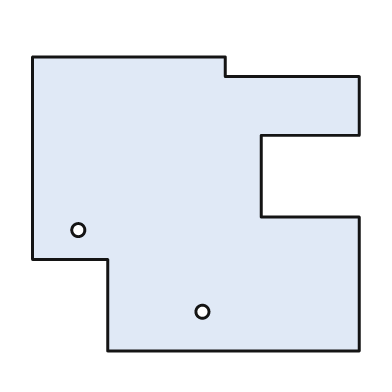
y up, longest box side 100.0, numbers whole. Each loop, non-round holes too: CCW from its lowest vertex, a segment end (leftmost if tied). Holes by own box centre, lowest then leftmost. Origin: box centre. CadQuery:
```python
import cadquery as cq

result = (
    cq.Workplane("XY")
    .moveTo(-27.0, -45.0)
    .lineTo(50.0, -45.0)
    .lineTo(50.0, -4.0)
    .lineTo(20.0, -4.0)
    .lineTo(20.0, 21.0)
    .lineTo(50.0, 21.0)
    .lineTo(50.0, 39.0)
    .lineTo(9.0, 39.0)
    .lineTo(9.0, 45.0)
    .lineTo(-50.0, 45.0)
    .lineTo(-50.0, -17.0)
    .lineTo(-27.0, -17.0)
    .close()
    .moveTo(2.0, -33.0)
    .circle(2.0)
    .moveTo(-36.0, -8.0)
    .circle(2.0)
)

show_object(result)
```